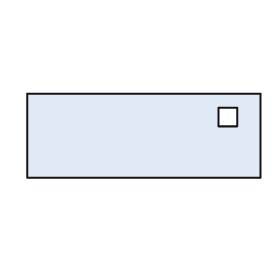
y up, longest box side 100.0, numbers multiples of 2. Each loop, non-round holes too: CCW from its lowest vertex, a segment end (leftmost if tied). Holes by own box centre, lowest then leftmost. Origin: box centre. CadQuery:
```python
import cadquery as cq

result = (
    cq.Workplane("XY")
    .moveTo(-50.0, -18.0)
    .lineTo(50.0, -18.0)
    .lineTo(50.0, 18.0)
    .lineTo(-50.0, 18.0)
    .close()
    .moveTo(32.0, 4.0)
    .lineTo(40.0, 4.0)
    .lineTo(40.0, 12.0)
    .lineTo(32.0, 12.0)
    .close()
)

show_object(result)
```